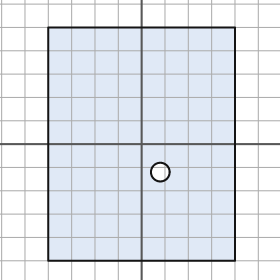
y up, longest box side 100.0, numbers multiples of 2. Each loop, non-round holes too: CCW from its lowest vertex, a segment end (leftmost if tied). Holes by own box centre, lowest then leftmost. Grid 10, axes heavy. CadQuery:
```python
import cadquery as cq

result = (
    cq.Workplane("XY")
    .moveTo(-40.0, -50.0)
    .lineTo(40.0, -50.0)
    .lineTo(40.0, 50.0)
    .lineTo(-40.0, 50.0)
    .close()
    .moveTo(8.0, -12.0)
    .circle(4.0)
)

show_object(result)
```